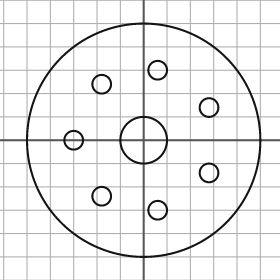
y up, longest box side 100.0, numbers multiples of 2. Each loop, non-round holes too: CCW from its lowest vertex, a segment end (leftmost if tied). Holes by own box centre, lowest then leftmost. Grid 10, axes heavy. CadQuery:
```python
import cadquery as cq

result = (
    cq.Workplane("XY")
    .moveTo(0.0, 0.0)
    .circle(50.0)
    .moveTo(6.0, -30.0)
    .circle(4.0)
    .moveTo(-18.0, -24.0)
    .circle(4.0)
    .moveTo(28.0, -14.0)
    .circle(4.0)
    .moveTo(-30.0, 0.0)
    .circle(4.0)
    .moveTo(0.0, 0.0)
    .circle(10.0)
    .moveTo(28.0, 14.0)
    .circle(4.0)
    .moveTo(-18.0, 24.0)
    .circle(4.0)
    .moveTo(6.0, 30.0)
    .circle(4.0)
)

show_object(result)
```